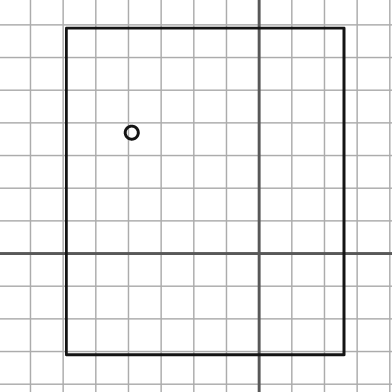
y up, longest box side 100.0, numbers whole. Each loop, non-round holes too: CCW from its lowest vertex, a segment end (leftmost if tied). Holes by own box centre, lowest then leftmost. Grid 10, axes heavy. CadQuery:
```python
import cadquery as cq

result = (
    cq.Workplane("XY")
    .moveTo(-59.0, -31.0)
    .lineTo(26.0, -31.0)
    .lineTo(26.0, 69.0)
    .lineTo(-59.0, 69.0)
    .close()
    .moveTo(-39.0, 37.0)
    .circle(2.0)
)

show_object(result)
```